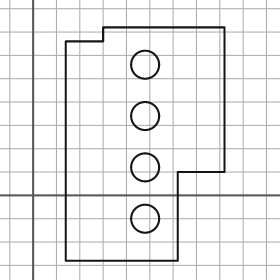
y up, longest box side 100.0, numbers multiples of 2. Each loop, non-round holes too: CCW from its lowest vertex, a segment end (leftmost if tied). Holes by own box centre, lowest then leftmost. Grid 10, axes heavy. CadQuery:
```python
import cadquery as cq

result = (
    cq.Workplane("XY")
    .moveTo(14.0, -28.0)
    .lineTo(62.0, -28.0)
    .lineTo(62.0, 10.0)
    .lineTo(82.0, 10.0)
    .lineTo(82.0, 72.0)
    .lineTo(30.0, 72.0)
    .lineTo(30.0, 66.0)
    .lineTo(14.0, 66.0)
    .close()
    .moveTo(48.0, -10.0)
    .circle(6.0)
    .moveTo(48.0, 12.0)
    .circle(6.0)
    .moveTo(48.0, 34.0)
    .circle(6.0)
    .moveTo(48.0, 56.0)
    .circle(6.0)
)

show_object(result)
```